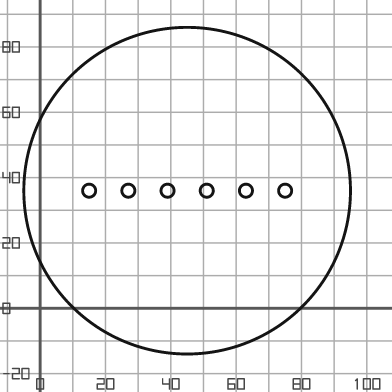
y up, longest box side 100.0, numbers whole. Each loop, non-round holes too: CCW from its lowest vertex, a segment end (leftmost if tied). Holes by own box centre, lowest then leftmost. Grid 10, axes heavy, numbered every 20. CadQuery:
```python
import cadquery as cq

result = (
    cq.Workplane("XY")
    .moveTo(45.0, 36.0)
    .circle(50.0)
    .moveTo(15.0, 36.0)
    .circle(2.0)
    .moveTo(27.0, 36.0)
    .circle(2.0)
    .moveTo(39.0, 36.0)
    .circle(2.0)
    .moveTo(51.0, 36.0)
    .circle(2.0)
    .moveTo(63.0, 36.0)
    .circle(2.0)
    .moveTo(75.0, 36.0)
    .circle(2.0)
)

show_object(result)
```